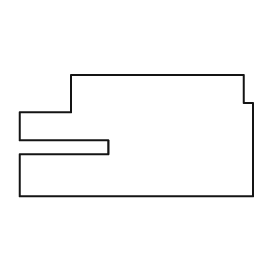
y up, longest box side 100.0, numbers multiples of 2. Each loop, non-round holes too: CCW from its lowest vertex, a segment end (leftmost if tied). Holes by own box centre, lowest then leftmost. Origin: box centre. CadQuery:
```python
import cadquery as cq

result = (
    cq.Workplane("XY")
    .moveTo(-50.0, -26.0)
    .lineTo(50.0, -26.0)
    .lineTo(50.0, 14.0)
    .lineTo(46.0, 14.0)
    .lineTo(46.0, 26.0)
    .lineTo(-28.0, 26.0)
    .lineTo(-28.0, 10.0)
    .lineTo(-50.0, 10.0)
    .lineTo(-50.0, -2.0)
    .lineTo(-12.0, -2.0)
    .lineTo(-12.0, -8.0)
    .lineTo(-50.0, -8.0)
    .close()
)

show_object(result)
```